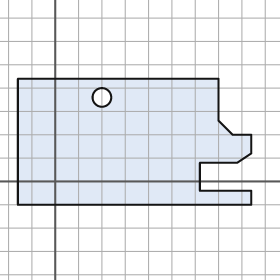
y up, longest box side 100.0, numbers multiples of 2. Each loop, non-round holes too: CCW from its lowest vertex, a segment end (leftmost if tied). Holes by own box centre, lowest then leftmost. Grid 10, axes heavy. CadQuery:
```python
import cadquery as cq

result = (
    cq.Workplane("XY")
    .moveTo(-16.0, -10.0)
    .lineTo(84.0, -10.0)
    .lineTo(84.0, -4.0)
    .lineTo(62.0, -4.0)
    .lineTo(62.0, 8.0)
    .lineTo(78.0, 8.0)
    .lineTo(84.0, 12.0)
    .lineTo(84.0, 20.0)
    .lineTo(76.0, 20.0)
    .lineTo(70.0, 26.0)
    .lineTo(70.0, 44.0)
    .lineTo(-16.0, 44.0)
    .close()
    .moveTo(20.0, 36.0)
    .circle(4.0)
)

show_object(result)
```